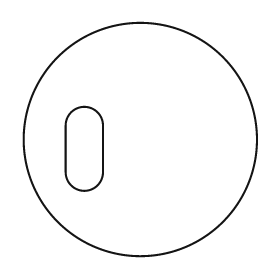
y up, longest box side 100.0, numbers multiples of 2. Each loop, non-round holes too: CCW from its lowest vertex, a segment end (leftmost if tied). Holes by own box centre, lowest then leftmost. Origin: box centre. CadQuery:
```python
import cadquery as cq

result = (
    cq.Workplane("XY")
    .moveTo(0.0, 0.0)
    .circle(50.0)
    .moveTo(-32.0, -14.0)
    .threePointArc((-24.0, -22.0), (-16.0, -14.0))
    .lineTo(-16.0, 6.0)
    .threePointArc((-24.0, 14.0), (-32.0, 6.0))
    .close()
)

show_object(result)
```